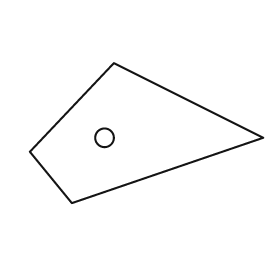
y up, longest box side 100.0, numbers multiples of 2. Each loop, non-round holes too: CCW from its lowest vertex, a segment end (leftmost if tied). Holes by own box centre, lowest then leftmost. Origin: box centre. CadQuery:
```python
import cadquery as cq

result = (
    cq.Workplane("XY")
    .moveTo(-32.0, -30.0)
    .lineTo(50.0, -2.0)
    .lineTo(-14.0, 30.0)
    .lineTo(-50.0, -8.0)
    .close()
    .moveTo(-18.0, -2.0)
    .circle(4.0)
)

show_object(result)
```